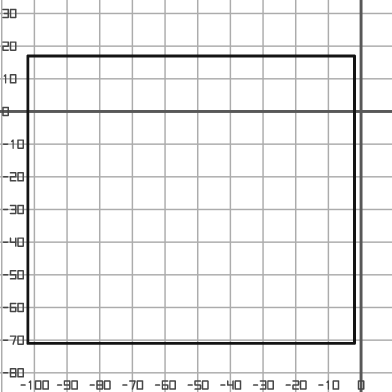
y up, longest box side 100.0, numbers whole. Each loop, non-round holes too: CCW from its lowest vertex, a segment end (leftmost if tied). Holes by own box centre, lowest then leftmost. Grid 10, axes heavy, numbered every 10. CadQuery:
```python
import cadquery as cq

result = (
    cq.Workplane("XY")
    .moveTo(-102.0, -71.0)
    .lineTo(-2.0, -71.0)
    .lineTo(-2.0, 17.0)
    .lineTo(-102.0, 17.0)
    .close()
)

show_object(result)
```